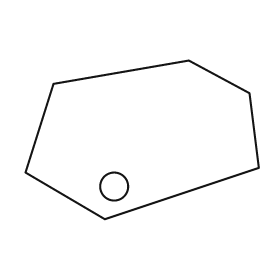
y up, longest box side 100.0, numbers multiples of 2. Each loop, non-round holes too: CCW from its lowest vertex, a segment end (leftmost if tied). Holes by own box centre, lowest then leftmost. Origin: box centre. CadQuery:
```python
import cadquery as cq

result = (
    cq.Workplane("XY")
    .moveTo(-16.0, -34.0)
    .lineTo(50.0, -12.0)
    .lineTo(46.0, 20.0)
    .lineTo(20.0, 34.0)
    .lineTo(-38.0, 24.0)
    .lineTo(-50.0, -14.0)
    .close()
    .moveTo(-12.0, -20.0)
    .circle(6.0)
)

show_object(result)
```